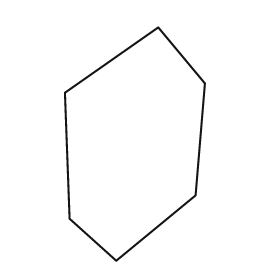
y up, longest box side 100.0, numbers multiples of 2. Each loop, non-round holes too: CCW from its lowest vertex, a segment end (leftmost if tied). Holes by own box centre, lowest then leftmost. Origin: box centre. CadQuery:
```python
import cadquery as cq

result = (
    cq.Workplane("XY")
    .moveTo(-8.0, -50.0)
    .lineTo(26.0, -22.0)
    .lineTo(30.0, 26.0)
    .lineTo(10.0, 50.0)
    .lineTo(-30.0, 22.0)
    .lineTo(-28.0, -32.0)
    .close()
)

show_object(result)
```